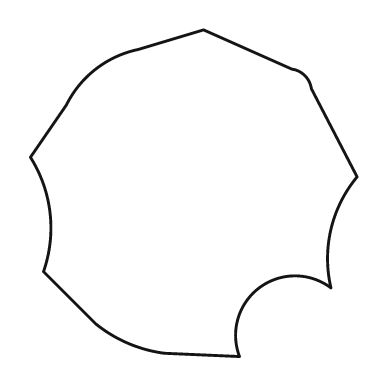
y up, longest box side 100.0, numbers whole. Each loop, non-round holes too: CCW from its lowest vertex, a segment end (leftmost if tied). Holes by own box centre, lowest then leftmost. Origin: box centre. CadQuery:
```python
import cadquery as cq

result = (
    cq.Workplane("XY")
    .moveTo(14.0, -50.0)
    .threePointArc((20.0, -29.0), (42.0, -29.0))
    .threePointArc((42.0, -11.0), (50.0, 5.0))
    .lineTo(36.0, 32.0)
    .threePointArc((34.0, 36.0), (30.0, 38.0))
    .lineTo(3.0, 50.0)
    .lineTo(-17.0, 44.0)
    .threePointArc((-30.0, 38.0), (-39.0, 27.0))
    .lineTo(-50.0, 11.0)
    .threePointArc((-44.0, -6.0), (-46.0, -24.0))
    .lineTo(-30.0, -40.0)
    .threePointArc((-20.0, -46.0), (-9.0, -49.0))
    .close()
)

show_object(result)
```